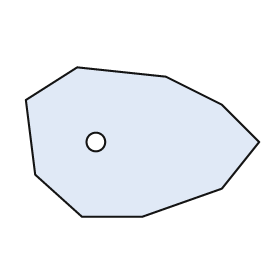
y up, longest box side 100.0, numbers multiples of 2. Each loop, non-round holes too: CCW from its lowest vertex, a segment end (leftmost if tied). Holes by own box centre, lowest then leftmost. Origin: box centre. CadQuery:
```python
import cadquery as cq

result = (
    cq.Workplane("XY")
    .moveTo(-26.0, -32.0)
    .lineTo(0.0, -32.0)
    .lineTo(34.0, -20.0)
    .lineTo(50.0, 0.0)
    .lineTo(34.0, 16.0)
    .lineTo(10.0, 28.0)
    .lineTo(-28.0, 32.0)
    .lineTo(-50.0, 18.0)
    .lineTo(-46.0, -14.0)
    .close()
    .moveTo(-20.0, 0.0)
    .circle(4.0)
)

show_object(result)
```